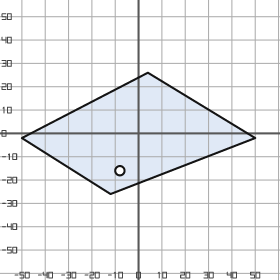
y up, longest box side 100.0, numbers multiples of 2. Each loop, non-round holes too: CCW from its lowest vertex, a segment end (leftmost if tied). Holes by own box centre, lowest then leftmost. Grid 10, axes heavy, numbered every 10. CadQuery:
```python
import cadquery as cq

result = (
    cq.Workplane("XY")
    .moveTo(-12.0, -26.0)
    .lineTo(50.0, -2.0)
    .lineTo(4.0, 26.0)
    .lineTo(-50.0, -2.0)
    .close()
    .moveTo(-8.0, -16.0)
    .circle(2.0)
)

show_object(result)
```